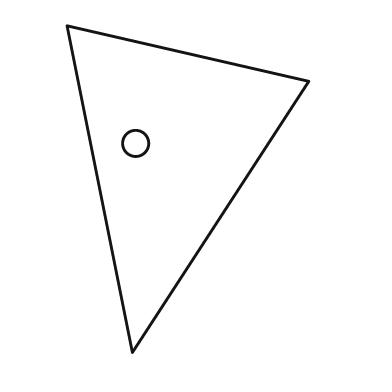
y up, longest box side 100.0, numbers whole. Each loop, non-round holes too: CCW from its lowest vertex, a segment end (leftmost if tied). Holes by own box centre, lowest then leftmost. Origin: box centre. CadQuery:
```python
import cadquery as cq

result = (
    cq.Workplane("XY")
    .moveTo(-17.0, -50.0)
    .lineTo(37.0, 33.0)
    .lineTo(-37.0, 50.0)
    .close()
    .moveTo(-16.0, 14.0)
    .circle(4.0)
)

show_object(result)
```